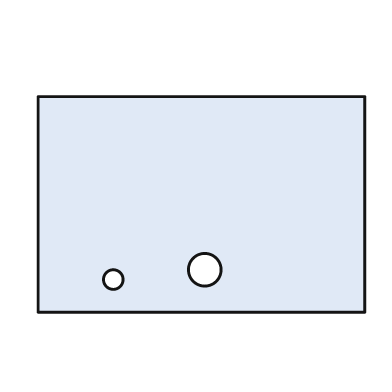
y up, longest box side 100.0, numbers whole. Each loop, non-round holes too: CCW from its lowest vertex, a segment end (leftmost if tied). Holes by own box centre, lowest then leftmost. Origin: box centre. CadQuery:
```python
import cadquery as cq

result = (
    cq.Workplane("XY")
    .moveTo(-50.0, -33.0)
    .lineTo(50.0, -33.0)
    .lineTo(50.0, 33.0)
    .lineTo(-50.0, 33.0)
    .close()
    .moveTo(-27.0, -23.0)
    .circle(3.0)
    .moveTo(1.0, -20.0)
    .circle(5.0)
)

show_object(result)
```